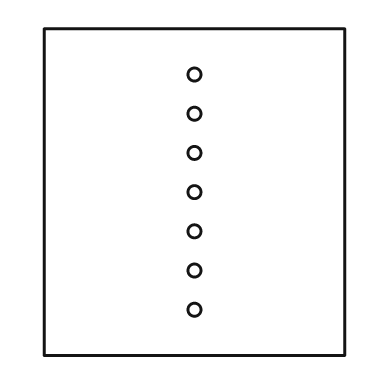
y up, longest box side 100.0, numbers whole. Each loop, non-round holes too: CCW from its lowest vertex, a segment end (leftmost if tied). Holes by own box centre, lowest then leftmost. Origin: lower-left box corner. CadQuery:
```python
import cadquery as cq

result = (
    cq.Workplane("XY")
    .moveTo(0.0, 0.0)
    .lineTo(92.0, 0.0)
    .lineTo(92.0, 100.0)
    .lineTo(0.0, 100.0)
    .close()
    .moveTo(46.0, 14.0)
    .circle(2.0)
    .moveTo(46.0, 26.0)
    .circle(2.0)
    .moveTo(46.0, 38.0)
    .circle(2.0)
    .moveTo(46.0, 50.0)
    .circle(2.0)
    .moveTo(46.0, 62.0)
    .circle(2.0)
    .moveTo(46.0, 74.0)
    .circle(2.0)
    .moveTo(46.0, 86.0)
    .circle(2.0)
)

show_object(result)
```